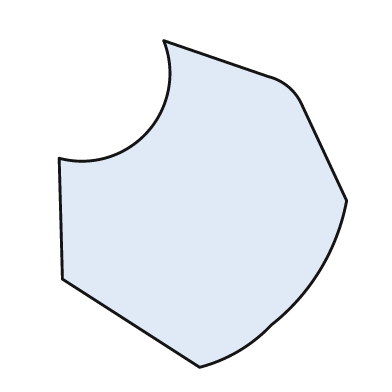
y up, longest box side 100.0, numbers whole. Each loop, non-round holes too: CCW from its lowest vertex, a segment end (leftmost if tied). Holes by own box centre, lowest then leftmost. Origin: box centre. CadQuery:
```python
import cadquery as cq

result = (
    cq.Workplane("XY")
    .moveTo(-1.0, -50.0)
    .threePointArc((11.0, -45.0), (21.0, -37.0))
    .threePointArc((36.0, -20.0), (44.0, 1.0))
    .lineTo(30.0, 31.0)
    .threePointArc((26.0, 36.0), (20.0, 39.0))
    .lineTo(-12.0, 50.0)
    .threePointArc((-17.0, 22.0), (-44.0, 14.0))
    .lineTo(-43.0, -23.0)
    .close()
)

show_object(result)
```